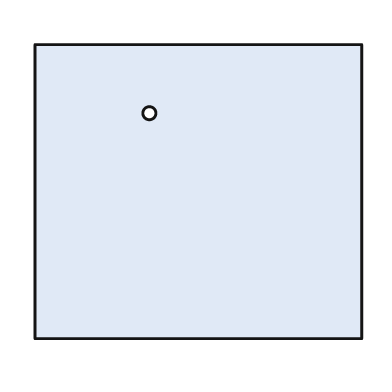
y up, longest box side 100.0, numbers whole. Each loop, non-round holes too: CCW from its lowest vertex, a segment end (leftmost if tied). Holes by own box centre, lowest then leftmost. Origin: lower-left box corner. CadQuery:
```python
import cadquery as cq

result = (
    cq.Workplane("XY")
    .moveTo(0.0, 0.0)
    .lineTo(100.0, 0.0)
    .lineTo(100.0, 90.0)
    .lineTo(0.0, 90.0)
    .close()
    .moveTo(35.0, 69.0)
    .circle(2.0)
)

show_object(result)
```